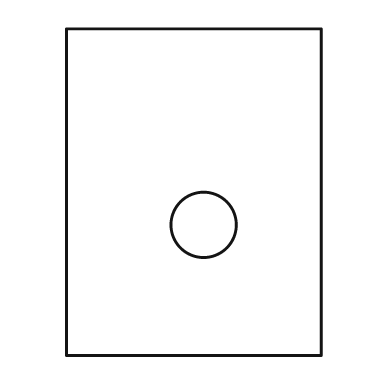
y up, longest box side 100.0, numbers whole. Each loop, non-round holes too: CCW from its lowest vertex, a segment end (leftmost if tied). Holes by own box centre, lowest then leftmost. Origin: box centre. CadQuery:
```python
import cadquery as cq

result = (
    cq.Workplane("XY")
    .moveTo(-39.0, -50.0)
    .lineTo(39.0, -50.0)
    .lineTo(39.0, 50.0)
    .lineTo(-39.0, 50.0)
    .close()
    .moveTo(3.0, -10.0)
    .circle(10.0)
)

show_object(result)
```